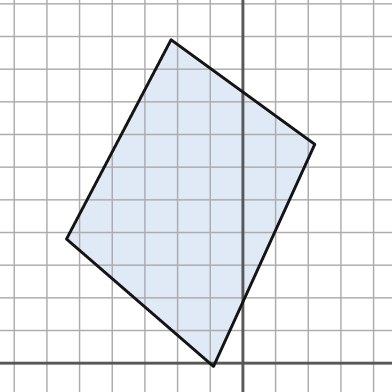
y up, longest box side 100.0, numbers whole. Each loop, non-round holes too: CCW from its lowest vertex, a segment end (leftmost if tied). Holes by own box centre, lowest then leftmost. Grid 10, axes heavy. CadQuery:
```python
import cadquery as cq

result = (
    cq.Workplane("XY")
    .moveTo(-9.0, -1.0)
    .lineTo(22.0, 67.0)
    .lineTo(-22.0, 99.0)
    .lineTo(-54.0, 38.0)
    .close()
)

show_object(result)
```